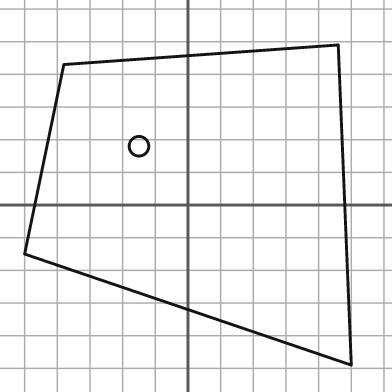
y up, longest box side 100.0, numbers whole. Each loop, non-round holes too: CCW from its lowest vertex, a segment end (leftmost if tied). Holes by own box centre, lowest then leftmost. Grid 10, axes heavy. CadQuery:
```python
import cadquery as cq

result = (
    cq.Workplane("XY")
    .moveTo(50.0, -49.0)
    .lineTo(46.0, 49.0)
    .lineTo(-38.0, 43.0)
    .lineTo(-50.0, -15.0)
    .close()
    .moveTo(-15.0, 18.0)
    .circle(3.0)
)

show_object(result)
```